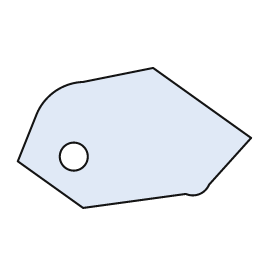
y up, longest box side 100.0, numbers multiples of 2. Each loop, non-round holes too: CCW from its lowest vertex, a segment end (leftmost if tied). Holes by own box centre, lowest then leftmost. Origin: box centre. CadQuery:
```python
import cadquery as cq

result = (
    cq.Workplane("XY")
    .moveTo(-22.0, -30.0)
    .lineTo(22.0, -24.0)
    .threePointArc((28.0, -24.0), (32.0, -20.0))
    .lineTo(50.0, 0.0)
    .lineTo(8.0, 30.0)
    .lineTo(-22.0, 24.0)
    .threePointArc((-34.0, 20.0), (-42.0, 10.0))
    .lineTo(-50.0, -10.0)
    .close()
    .moveTo(-26.0, -8.0)
    .circle(6.0)
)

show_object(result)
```